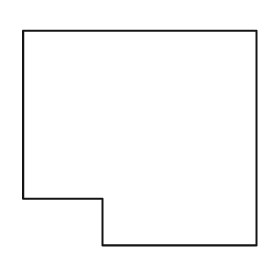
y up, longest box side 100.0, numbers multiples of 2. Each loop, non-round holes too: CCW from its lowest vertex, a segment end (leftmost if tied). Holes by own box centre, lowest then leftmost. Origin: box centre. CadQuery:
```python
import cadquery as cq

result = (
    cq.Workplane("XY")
    .moveTo(-16.0, -46.0)
    .lineTo(50.0, -46.0)
    .lineTo(50.0, 46.0)
    .lineTo(-50.0, 46.0)
    .lineTo(-50.0, -26.0)
    .lineTo(-16.0, -26.0)
    .close()
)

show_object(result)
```